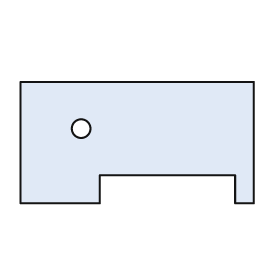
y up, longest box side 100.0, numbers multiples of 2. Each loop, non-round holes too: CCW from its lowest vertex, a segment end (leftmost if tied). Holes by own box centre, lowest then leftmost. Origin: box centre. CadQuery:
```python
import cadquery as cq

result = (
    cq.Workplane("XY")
    .moveTo(-50.0, -26.0)
    .lineTo(-16.0, -26.0)
    .lineTo(-16.0, -14.0)
    .lineTo(42.0, -14.0)
    .lineTo(42.0, -26.0)
    .lineTo(50.0, -26.0)
    .lineTo(50.0, 26.0)
    .lineTo(-50.0, 26.0)
    .close()
    .moveTo(-24.0, 6.0)
    .circle(4.0)
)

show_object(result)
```